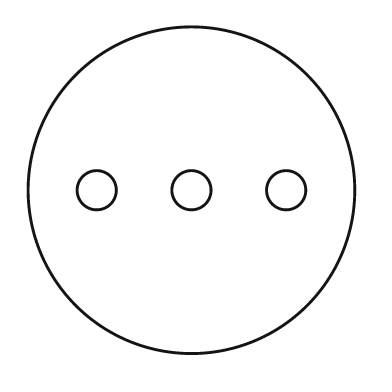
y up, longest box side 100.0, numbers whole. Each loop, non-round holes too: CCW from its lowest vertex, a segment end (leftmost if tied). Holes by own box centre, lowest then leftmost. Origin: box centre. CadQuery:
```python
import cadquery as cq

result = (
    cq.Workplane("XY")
    .moveTo(0.0, 0.0)
    .circle(50.0)
    .moveTo(-29.0, 0.0)
    .circle(6.0)
    .moveTo(0.0, 0.0)
    .circle(6.0)
    .moveTo(29.0, 0.0)
    .circle(6.0)
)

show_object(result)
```